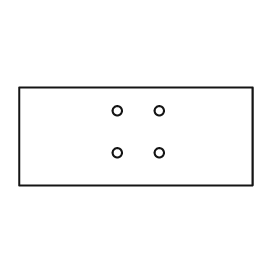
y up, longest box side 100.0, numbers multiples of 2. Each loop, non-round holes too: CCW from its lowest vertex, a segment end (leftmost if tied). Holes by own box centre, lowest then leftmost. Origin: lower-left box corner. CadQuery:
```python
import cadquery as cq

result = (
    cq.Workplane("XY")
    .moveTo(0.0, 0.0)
    .lineTo(100.0, 0.0)
    .lineTo(100.0, 42.0)
    .lineTo(0.0, 42.0)
    .close()
    .moveTo(42.0, 14.0)
    .circle(2.0)
    .moveTo(60.0, 14.0)
    .circle(2.0)
    .moveTo(42.0, 32.0)
    .circle(2.0)
    .moveTo(60.0, 32.0)
    .circle(2.0)
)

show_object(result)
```